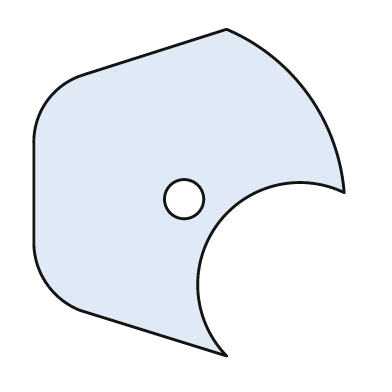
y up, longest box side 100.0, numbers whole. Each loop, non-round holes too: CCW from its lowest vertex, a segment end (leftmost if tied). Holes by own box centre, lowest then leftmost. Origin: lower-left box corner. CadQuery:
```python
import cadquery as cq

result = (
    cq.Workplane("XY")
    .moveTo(59.0, 0.0)
    .threePointArc((56.0, 40.0), (95.0, 50.0))
    .threePointArc((84.0, 80.0), (59.0, 100.0))
    .lineTo(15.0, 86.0)
    .threePointArc((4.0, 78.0), (0.0, 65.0))
    .lineTo(0.0, 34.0)
    .threePointArc((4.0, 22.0), (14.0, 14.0))
    .close()
    .moveTo(46.0, 48.0)
    .circle(6.0)
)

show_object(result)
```